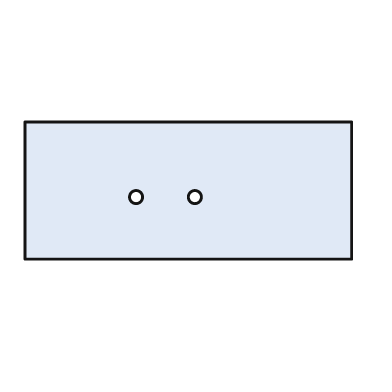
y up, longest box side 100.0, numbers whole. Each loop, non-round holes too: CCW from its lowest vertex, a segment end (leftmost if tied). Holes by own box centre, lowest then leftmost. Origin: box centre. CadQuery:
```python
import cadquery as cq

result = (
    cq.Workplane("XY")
    .moveTo(-50.0, -21.0)
    .lineTo(50.0, -21.0)
    .lineTo(50.0, 21.0)
    .lineTo(-50.0, 21.0)
    .close()
    .moveTo(-16.0, -2.0)
    .circle(2.0)
    .moveTo(2.0, -2.0)
    .circle(2.0)
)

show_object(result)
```